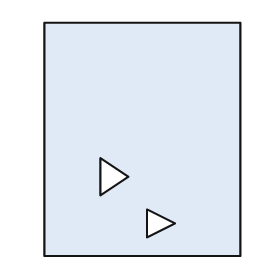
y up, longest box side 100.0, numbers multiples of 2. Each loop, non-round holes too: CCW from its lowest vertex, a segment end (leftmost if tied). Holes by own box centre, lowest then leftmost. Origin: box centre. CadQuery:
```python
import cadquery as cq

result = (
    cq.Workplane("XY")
    .moveTo(-42.0, -50.0)
    .lineTo(42.0, -50.0)
    .lineTo(42.0, 50.0)
    .lineTo(-42.0, 50.0)
    .close()
    .moveTo(2.0, -42.0)
    .lineTo(14.0, -36.0)
    .lineTo(2.0, -30.0)
    .close()
    .moveTo(-18.0, -24.0)
    .lineTo(-6.0, -16.0)
    .lineTo(-18.0, -8.0)
    .close()
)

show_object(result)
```